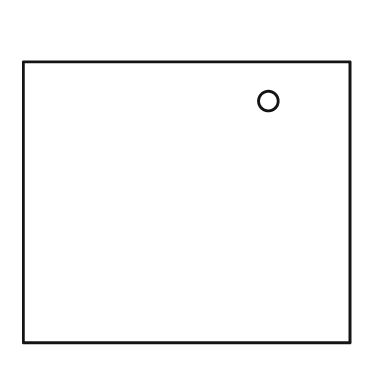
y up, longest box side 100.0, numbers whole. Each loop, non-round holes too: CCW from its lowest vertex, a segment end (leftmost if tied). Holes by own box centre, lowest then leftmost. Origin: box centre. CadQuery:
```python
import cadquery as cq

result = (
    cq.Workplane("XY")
    .moveTo(-50.0, -43.0)
    .lineTo(50.0, -43.0)
    .lineTo(50.0, 43.0)
    .lineTo(-50.0, 43.0)
    .close()
    .moveTo(25.0, 31.0)
    .circle(3.0)
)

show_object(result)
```